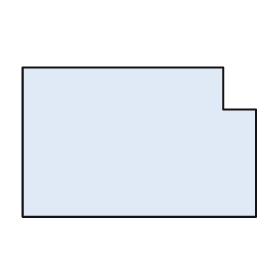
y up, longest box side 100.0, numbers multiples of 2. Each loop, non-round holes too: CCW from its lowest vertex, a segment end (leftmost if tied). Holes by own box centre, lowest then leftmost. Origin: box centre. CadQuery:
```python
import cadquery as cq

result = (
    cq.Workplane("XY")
    .moveTo(-50.0, -32.0)
    .lineTo(50.0, -32.0)
    .lineTo(50.0, 14.0)
    .lineTo(36.0, 14.0)
    .lineTo(36.0, 32.0)
    .lineTo(-50.0, 32.0)
    .close()
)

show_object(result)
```